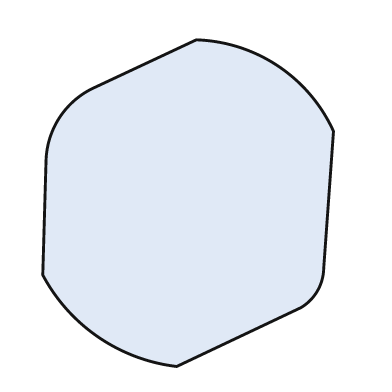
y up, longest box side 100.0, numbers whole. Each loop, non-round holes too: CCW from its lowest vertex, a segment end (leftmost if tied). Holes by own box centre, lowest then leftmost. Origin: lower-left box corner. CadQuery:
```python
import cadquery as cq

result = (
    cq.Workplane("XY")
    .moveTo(41.0, 0.0)
    .lineTo(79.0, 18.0)
    .threePointArc((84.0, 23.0), (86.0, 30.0))
    .lineTo(89.0, 72.0)
    .threePointArc((72.0, 92.0), (47.0, 100.0))
    .lineTo(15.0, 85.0)
    .threePointArc((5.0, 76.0), (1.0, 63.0))
    .lineTo(0.0, 28.0)
    .threePointArc((17.0, 9.0), (41.0, 0.0))
    .close()
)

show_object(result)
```